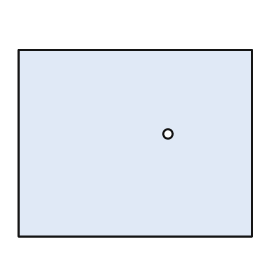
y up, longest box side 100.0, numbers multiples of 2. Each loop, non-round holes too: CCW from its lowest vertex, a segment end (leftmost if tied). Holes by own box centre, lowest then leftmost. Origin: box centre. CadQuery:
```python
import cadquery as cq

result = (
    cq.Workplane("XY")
    .moveTo(-50.0, -40.0)
    .lineTo(50.0, -40.0)
    .lineTo(50.0, 40.0)
    .lineTo(-50.0, 40.0)
    .close()
    .moveTo(14.0, 4.0)
    .circle(2.0)
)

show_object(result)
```